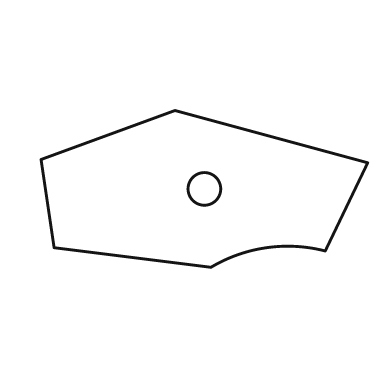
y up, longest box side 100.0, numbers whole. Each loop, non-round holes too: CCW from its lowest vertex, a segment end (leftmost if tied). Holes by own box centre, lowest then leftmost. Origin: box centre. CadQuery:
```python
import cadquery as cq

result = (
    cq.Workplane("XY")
    .moveTo(2.0, -24.0)
    .threePointArc((19.0, -18.0), (37.0, -19.0))
    .lineTo(50.0, 8.0)
    .lineTo(-9.0, 24.0)
    .lineTo(-50.0, 9.0)
    .lineTo(-46.0, -18.0)
    .close()
    .moveTo(0.0, 0.0)
    .circle(5.0)
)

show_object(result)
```